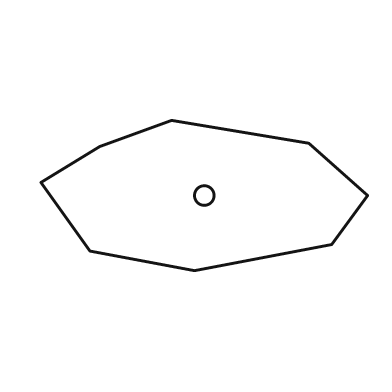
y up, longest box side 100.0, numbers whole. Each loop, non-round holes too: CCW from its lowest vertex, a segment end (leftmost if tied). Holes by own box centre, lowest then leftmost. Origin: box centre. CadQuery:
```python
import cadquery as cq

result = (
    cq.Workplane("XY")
    .moveTo(-3.0, -23.0)
    .lineTo(39.0, -15.0)
    .lineTo(50.0, 0.0)
    .lineTo(32.0, 16.0)
    .lineTo(-10.0, 23.0)
    .lineTo(-32.0, 15.0)
    .lineTo(-50.0, 4.0)
    .lineTo(-35.0, -17.0)
    .close()
    .moveTo(0.0, 0.0)
    .circle(3.0)
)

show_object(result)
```